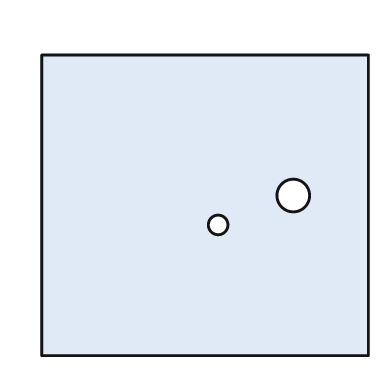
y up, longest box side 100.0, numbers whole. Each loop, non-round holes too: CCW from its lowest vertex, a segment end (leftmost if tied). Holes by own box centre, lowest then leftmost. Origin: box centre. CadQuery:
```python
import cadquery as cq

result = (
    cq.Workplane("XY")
    .moveTo(-50.0, -46.0)
    .lineTo(50.0, -46.0)
    .lineTo(50.0, 46.0)
    .lineTo(-50.0, 46.0)
    .close()
    .moveTo(4.0, -6.0)
    .circle(3.0)
    .moveTo(27.0, 3.0)
    .circle(5.0)
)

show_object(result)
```